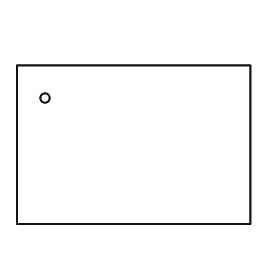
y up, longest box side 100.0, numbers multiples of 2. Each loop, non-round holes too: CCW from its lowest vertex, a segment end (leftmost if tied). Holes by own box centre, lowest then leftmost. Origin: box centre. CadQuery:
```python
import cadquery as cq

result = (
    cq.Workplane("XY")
    .moveTo(-50.0, -34.0)
    .lineTo(50.0, -34.0)
    .lineTo(50.0, 34.0)
    .lineTo(-50.0, 34.0)
    .close()
    .moveTo(-38.0, 20.0)
    .circle(2.0)
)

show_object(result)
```